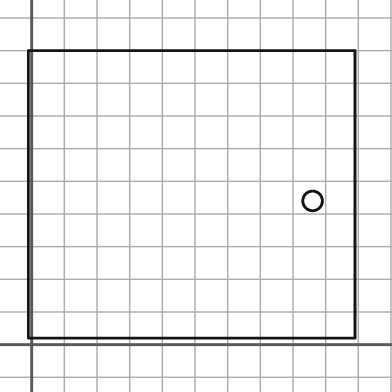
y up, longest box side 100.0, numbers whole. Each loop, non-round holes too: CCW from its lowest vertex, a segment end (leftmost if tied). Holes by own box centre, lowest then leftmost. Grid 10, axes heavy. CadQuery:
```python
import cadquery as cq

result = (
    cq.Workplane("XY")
    .moveTo(-1.0, 2.0)
    .lineTo(99.0, 2.0)
    .lineTo(99.0, 90.0)
    .lineTo(-1.0, 90.0)
    .close()
    .moveTo(86.0, 44.0)
    .circle(3.0)
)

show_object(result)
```